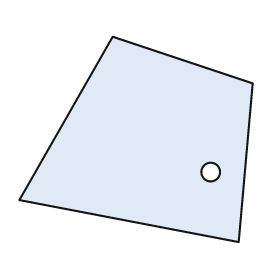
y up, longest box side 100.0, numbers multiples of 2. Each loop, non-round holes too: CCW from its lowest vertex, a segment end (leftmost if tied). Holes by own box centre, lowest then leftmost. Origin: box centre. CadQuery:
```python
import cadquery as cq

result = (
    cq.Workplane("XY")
    .moveTo(44.0, -44.0)
    .lineTo(50.0, 24.0)
    .lineTo(-10.0, 44.0)
    .lineTo(-50.0, -26.0)
    .close()
    .moveTo(32.0, -14.0)
    .circle(4.0)
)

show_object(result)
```